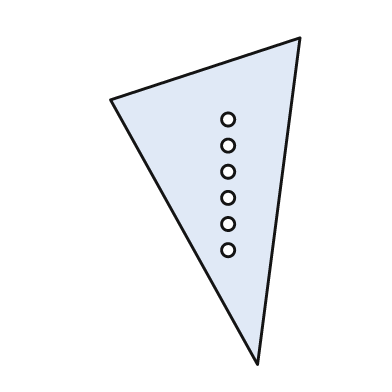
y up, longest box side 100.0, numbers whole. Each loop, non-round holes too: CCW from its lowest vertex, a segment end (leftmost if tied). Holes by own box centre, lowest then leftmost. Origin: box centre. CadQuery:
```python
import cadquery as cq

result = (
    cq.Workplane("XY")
    .moveTo(16.0, -50.0)
    .lineTo(29.0, 50.0)
    .lineTo(-29.0, 31.0)
    .close()
    .moveTo(7.0, -15.0)
    .circle(2.0)
    .moveTo(7.0, -7.0)
    .circle(2.0)
    .moveTo(7.0, 1.0)
    .circle(2.0)
    .moveTo(7.0, 9.0)
    .circle(2.0)
    .moveTo(7.0, 17.0)
    .circle(2.0)
    .moveTo(7.0, 25.0)
    .circle(2.0)
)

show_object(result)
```